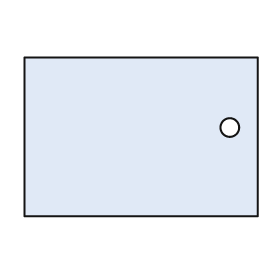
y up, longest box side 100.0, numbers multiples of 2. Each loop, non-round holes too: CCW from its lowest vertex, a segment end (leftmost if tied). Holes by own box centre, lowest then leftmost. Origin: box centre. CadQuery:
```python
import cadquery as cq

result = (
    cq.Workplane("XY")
    .moveTo(-50.0, -34.0)
    .lineTo(50.0, -34.0)
    .lineTo(50.0, 34.0)
    .lineTo(-50.0, 34.0)
    .close()
    .moveTo(38.0, 4.0)
    .circle(4.0)
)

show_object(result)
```